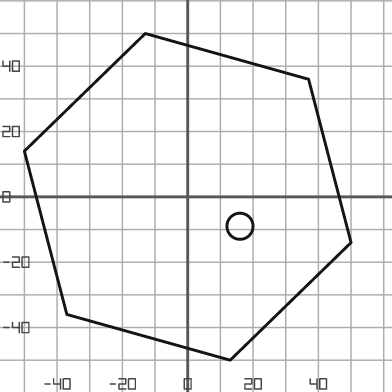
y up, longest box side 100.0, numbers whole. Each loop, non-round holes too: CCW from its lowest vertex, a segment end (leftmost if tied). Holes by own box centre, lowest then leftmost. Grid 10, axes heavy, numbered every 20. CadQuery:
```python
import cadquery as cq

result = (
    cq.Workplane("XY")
    .moveTo(13.0, -50.0)
    .lineTo(50.0, -14.0)
    .lineTo(37.0, 36.0)
    .lineTo(-13.0, 50.0)
    .lineTo(-50.0, 14.0)
    .lineTo(-37.0, -36.0)
    .close()
    .moveTo(16.0, -9.0)
    .circle(4.0)
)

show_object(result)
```